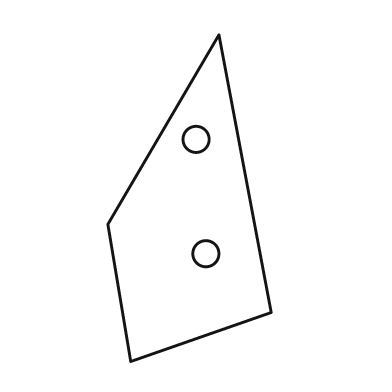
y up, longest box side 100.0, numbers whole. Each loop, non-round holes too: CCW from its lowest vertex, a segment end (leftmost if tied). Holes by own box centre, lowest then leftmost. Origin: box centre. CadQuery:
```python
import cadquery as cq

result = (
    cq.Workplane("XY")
    .moveTo(-18.0, -50.0)
    .lineTo(25.0, -35.0)
    .lineTo(9.0, 50.0)
    .lineTo(-25.0, -8.0)
    .close()
    .moveTo(5.0, -17.0)
    .circle(4.0)
    .moveTo(2.0, 18.0)
    .circle(4.0)
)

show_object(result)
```